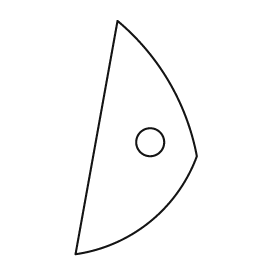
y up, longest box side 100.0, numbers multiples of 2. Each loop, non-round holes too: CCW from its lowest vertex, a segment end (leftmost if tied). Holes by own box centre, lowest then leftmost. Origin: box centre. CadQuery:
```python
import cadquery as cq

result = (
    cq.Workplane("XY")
    .moveTo(-26.0, -50.0)
    .threePointArc((6.0, -36.0), (26.0, -8.0))
    .threePointArc((14.0, 24.0), (-8.0, 50.0))
    .close()
    .moveTo(6.0, -2.0)
    .circle(6.0)
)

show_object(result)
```